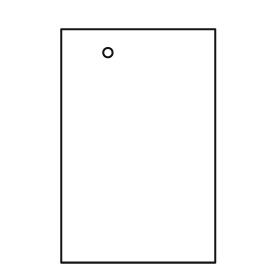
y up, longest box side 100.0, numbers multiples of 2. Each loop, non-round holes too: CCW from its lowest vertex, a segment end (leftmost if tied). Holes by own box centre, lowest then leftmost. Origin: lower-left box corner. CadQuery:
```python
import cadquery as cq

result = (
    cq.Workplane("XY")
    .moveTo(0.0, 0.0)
    .lineTo(66.0, 0.0)
    .lineTo(66.0, 100.0)
    .lineTo(0.0, 100.0)
    .close()
    .moveTo(20.0, 90.0)
    .circle(2.0)
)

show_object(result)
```